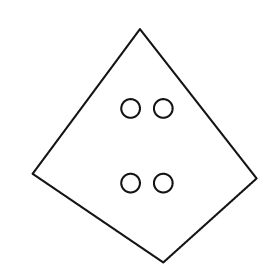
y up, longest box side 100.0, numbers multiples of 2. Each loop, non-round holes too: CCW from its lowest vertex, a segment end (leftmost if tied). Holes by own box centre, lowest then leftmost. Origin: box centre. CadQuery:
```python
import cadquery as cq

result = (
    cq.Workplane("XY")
    .moveTo(8.0, -50.0)
    .lineTo(48.0, -14.0)
    .lineTo(-2.0, 50.0)
    .lineTo(-48.0, -12.0)
    .close()
    .moveTo(-6.0, -16.0)
    .circle(4.0)
    .moveTo(8.0, -16.0)
    .circle(4.0)
    .moveTo(-6.0, 16.0)
    .circle(4.0)
    .moveTo(8.0, 16.0)
    .circle(4.0)
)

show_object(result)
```